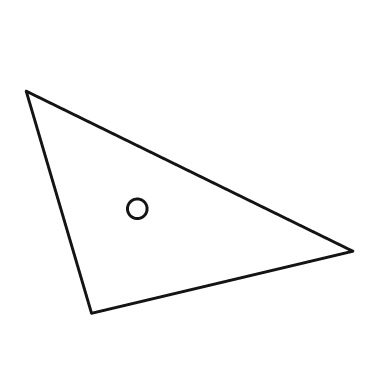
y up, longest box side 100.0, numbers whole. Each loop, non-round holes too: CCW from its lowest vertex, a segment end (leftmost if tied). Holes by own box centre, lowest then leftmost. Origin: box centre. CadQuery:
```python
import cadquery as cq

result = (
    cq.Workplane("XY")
    .moveTo(-30.0, -34.0)
    .lineTo(50.0, -15.0)
    .lineTo(-50.0, 34.0)
    .close()
    .moveTo(-16.0, -2.0)
    .circle(3.0)
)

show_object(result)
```